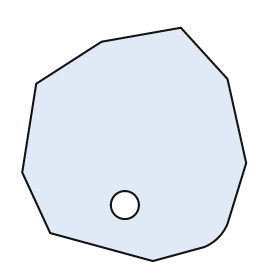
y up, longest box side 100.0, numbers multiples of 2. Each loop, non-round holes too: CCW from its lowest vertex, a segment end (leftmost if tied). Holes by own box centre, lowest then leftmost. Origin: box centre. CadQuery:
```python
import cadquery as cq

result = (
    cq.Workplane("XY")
    .moveTo(8.0, -50.0)
    .lineTo(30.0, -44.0)
    .threePointArc((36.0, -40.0), (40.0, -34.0))
    .lineTo(48.0, -8.0)
    .lineTo(40.0, 28.0)
    .lineTo(20.0, 50.0)
    .lineTo(-14.0, 44.0)
    .lineTo(-42.0, 26.0)
    .lineTo(-48.0, -12.0)
    .lineTo(-36.0, -38.0)
    .close()
    .moveTo(-4.0, -26.0)
    .circle(6.0)
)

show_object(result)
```